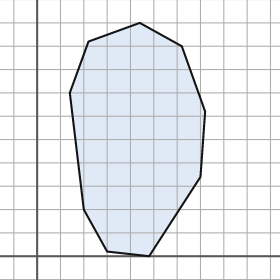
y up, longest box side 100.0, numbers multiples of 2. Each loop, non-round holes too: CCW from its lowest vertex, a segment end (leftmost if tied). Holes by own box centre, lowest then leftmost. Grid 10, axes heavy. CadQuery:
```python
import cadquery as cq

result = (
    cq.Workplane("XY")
    .moveTo(48.0, 0.0)
    .lineTo(70.0, 34.0)
    .lineTo(72.0, 62.0)
    .lineTo(62.0, 90.0)
    .lineTo(44.0, 100.0)
    .lineTo(22.0, 92.0)
    .lineTo(14.0, 70.0)
    .lineTo(20.0, 20.0)
    .lineTo(30.0, 2.0)
    .close()
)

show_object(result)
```